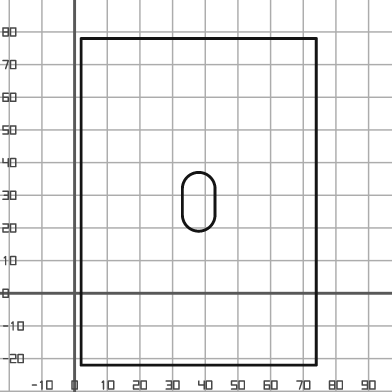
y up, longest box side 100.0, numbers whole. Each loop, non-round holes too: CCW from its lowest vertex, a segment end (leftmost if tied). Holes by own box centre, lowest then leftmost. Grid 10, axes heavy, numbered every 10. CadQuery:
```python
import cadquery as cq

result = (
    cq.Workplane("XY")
    .moveTo(2.0, -22.0)
    .lineTo(74.0, -22.0)
    .lineTo(74.0, 78.0)
    .lineTo(2.0, 78.0)
    .close()
    .moveTo(33.0, 24.0)
    .threePointArc((38.0, 19.0), (43.0, 24.0))
    .lineTo(43.0, 32.0)
    .threePointArc((38.0, 37.0), (33.0, 32.0))
    .close()
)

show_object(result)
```